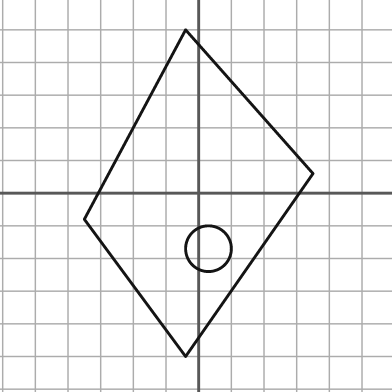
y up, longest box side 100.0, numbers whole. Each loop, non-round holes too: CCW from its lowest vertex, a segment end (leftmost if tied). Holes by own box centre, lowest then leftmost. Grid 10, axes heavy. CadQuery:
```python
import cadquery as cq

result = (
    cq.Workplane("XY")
    .moveTo(-4.0, -50.0)
    .lineTo(35.0, 6.0)
    .lineTo(-4.0, 50.0)
    .lineTo(-35.0, -8.0)
    .close()
    .moveTo(3.0, -17.0)
    .circle(7.0)
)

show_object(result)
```